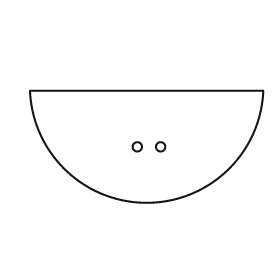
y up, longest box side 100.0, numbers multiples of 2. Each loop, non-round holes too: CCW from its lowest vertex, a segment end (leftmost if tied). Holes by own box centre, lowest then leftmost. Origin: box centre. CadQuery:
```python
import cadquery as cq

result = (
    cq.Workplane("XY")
    .moveTo(-50.0, 24.0)
    .threePointArc((0.0, -24.0), (50.0, 24.0))
    .close()
    .moveTo(-4.0, 0.0)
    .circle(2.0)
    .moveTo(6.0, 0.0)
    .circle(2.0)
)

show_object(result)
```